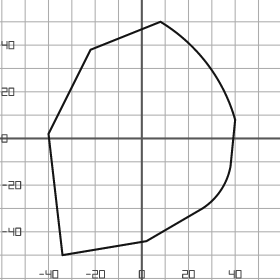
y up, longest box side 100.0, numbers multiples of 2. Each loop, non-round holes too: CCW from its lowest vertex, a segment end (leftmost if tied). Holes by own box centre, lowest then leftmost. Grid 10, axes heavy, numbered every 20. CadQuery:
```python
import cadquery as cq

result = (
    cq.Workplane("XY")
    .moveTo(-34.0, -50.0)
    .lineTo(2.0, -44.0)
    .lineTo(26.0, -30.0)
    .threePointArc((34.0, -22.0), (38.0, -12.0))
    .lineTo(40.0, 8.0)
    .threePointArc((28.0, 32.0), (8.0, 50.0))
    .lineTo(-22.0, 38.0)
    .lineTo(-40.0, 2.0)
    .close()
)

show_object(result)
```